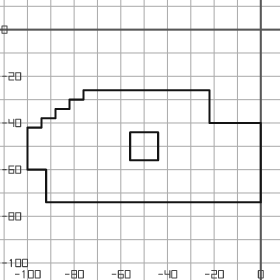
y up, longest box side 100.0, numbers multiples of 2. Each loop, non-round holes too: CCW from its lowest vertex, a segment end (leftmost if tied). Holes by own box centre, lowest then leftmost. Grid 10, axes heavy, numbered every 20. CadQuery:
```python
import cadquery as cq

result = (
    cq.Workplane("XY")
    .moveTo(-92.0, -74.0)
    .lineTo(0.0, -74.0)
    .lineTo(0.0, -40.0)
    .lineTo(-22.0, -40.0)
    .lineTo(-22.0, -26.0)
    .lineTo(-76.0, -26.0)
    .lineTo(-76.0, -30.0)
    .lineTo(-82.0, -30.0)
    .lineTo(-82.0, -34.0)
    .lineTo(-88.0, -34.0)
    .lineTo(-88.0, -38.0)
    .lineTo(-94.0, -38.0)
    .lineTo(-94.0, -42.0)
    .lineTo(-100.0, -42.0)
    .lineTo(-100.0, -60.0)
    .lineTo(-92.0, -60.0)
    .close()
    .moveTo(-56.0, -56.0)
    .lineTo(-44.0, -56.0)
    .lineTo(-44.0, -44.0)
    .lineTo(-56.0, -44.0)
    .close()
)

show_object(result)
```